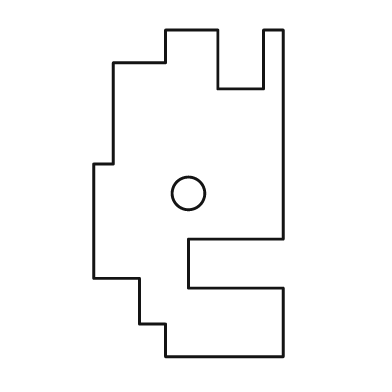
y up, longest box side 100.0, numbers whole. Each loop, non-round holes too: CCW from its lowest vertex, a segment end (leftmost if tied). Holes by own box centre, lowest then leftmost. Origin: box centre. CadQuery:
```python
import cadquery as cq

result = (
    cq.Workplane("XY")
    .moveTo(-7.0, -50.0)
    .lineTo(29.0, -50.0)
    .lineTo(29.0, -29.0)
    .lineTo(0.0, -29.0)
    .lineTo(0.0, -14.0)
    .lineTo(29.0, -14.0)
    .lineTo(29.0, 50.0)
    .lineTo(23.0, 50.0)
    .lineTo(23.0, 32.0)
    .lineTo(9.0, 32.0)
    .lineTo(9.0, 50.0)
    .lineTo(-7.0, 50.0)
    .lineTo(-7.0, 40.0)
    .lineTo(-23.0, 40.0)
    .lineTo(-23.0, 9.0)
    .lineTo(-29.0, 9.0)
    .lineTo(-29.0, -26.0)
    .lineTo(-15.0, -26.0)
    .lineTo(-15.0, -40.0)
    .lineTo(-7.0, -40.0)
    .close()
    .moveTo(0.0, 0.0)
    .circle(5.0)
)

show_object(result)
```